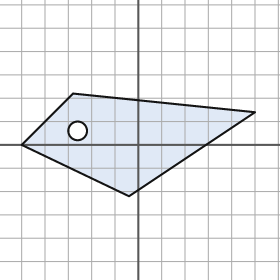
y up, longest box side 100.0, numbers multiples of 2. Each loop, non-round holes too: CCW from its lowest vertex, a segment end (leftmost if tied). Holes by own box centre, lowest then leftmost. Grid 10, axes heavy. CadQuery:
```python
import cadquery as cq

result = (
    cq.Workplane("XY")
    .moveTo(-4.0, -22.0)
    .lineTo(50.0, 14.0)
    .lineTo(-28.0, 22.0)
    .lineTo(-50.0, 0.0)
    .close()
    .moveTo(-26.0, 6.0)
    .circle(4.0)
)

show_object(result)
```